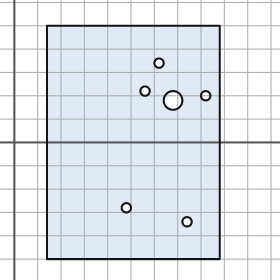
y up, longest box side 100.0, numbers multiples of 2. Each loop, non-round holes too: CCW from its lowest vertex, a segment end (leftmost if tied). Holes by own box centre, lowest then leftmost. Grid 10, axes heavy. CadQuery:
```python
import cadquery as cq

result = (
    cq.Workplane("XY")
    .moveTo(14.0, -50.0)
    .lineTo(88.0, -50.0)
    .lineTo(88.0, 50.0)
    .lineTo(14.0, 50.0)
    .close()
    .moveTo(74.0, -34.0)
    .circle(2.0)
    .moveTo(48.0, -28.0)
    .circle(2.0)
    .moveTo(68.0, 18.0)
    .circle(4.0)
    .moveTo(82.0, 20.0)
    .circle(2.0)
    .moveTo(56.0, 22.0)
    .circle(2.0)
    .moveTo(62.0, 34.0)
    .circle(2.0)
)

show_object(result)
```